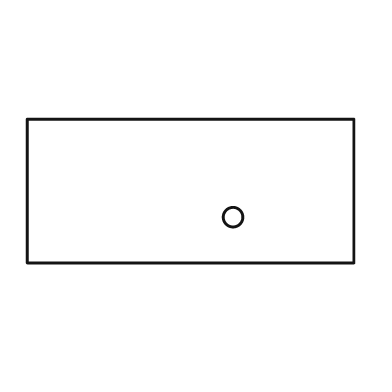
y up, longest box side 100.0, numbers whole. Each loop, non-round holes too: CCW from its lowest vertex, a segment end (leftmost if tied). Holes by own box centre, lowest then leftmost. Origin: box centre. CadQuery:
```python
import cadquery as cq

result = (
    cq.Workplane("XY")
    .moveTo(-50.0, -22.0)
    .lineTo(50.0, -22.0)
    .lineTo(50.0, 22.0)
    .lineTo(-50.0, 22.0)
    .close()
    .moveTo(13.0, -8.0)
    .circle(3.0)
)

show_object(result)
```